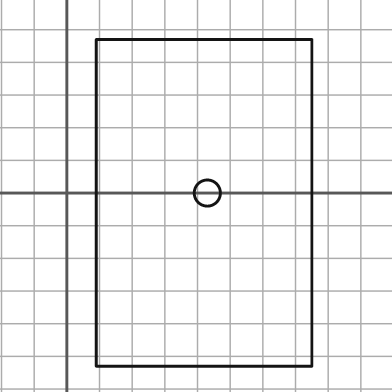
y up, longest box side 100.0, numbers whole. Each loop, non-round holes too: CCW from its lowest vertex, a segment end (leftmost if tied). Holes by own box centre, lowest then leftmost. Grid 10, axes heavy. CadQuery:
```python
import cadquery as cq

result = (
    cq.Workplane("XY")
    .moveTo(9.0, -53.0)
    .lineTo(75.0, -53.0)
    .lineTo(75.0, 47.0)
    .lineTo(9.0, 47.0)
    .close()
    .moveTo(43.0, 0.0)
    .circle(4.0)
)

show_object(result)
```